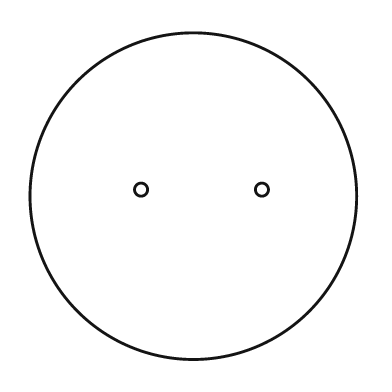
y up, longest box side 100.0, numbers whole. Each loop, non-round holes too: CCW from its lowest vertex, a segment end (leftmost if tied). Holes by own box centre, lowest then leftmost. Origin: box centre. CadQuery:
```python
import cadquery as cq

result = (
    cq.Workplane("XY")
    .moveTo(0.0, 0.0)
    .circle(50.0)
    .moveTo(-16.0, 2.0)
    .circle(2.0)
    .moveTo(21.0, 2.0)
    .circle(2.0)
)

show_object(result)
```